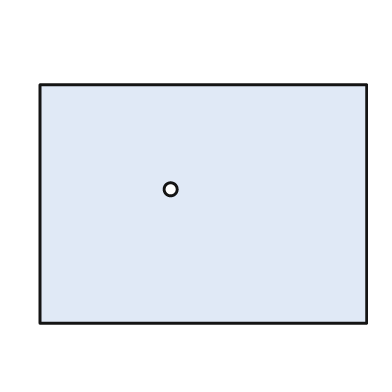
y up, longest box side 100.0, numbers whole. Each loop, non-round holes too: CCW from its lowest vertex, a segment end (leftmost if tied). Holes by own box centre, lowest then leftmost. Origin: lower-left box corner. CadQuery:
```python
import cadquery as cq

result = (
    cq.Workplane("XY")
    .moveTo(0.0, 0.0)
    .lineTo(100.0, 0.0)
    .lineTo(100.0, 73.0)
    .lineTo(0.0, 73.0)
    .close()
    .moveTo(40.0, 41.0)
    .circle(2.0)
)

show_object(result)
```